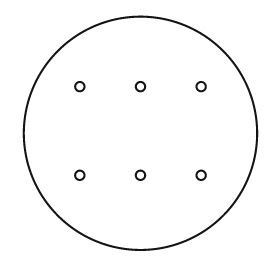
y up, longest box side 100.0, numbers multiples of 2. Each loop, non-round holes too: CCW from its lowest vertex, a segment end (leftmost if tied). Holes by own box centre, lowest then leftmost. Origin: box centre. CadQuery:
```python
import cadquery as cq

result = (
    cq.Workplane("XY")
    .moveTo(0.0, 0.0)
    .circle(50.0)
    .moveTo(-26.0, -18.0)
    .circle(2.0)
    .moveTo(0.0, -18.0)
    .circle(2.0)
    .moveTo(26.0, -18.0)
    .circle(2.0)
    .moveTo(-26.0, 20.0)
    .circle(2.0)
    .moveTo(0.0, 20.0)
    .circle(2.0)
    .moveTo(26.0, 20.0)
    .circle(2.0)
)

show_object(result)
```